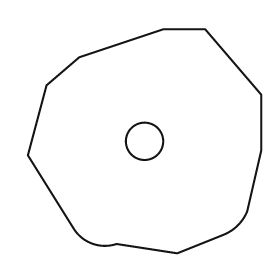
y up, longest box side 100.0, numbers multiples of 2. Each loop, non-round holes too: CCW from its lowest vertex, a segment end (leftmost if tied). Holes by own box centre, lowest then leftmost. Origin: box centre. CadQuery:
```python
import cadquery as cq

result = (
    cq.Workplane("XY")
    .moveTo(14.0, -48.0)
    .lineTo(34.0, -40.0)
    .threePointArc((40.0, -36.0), (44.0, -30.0))
    .lineTo(50.0, -4.0)
    .lineTo(50.0, 20.0)
    .lineTo(26.0, 48.0)
    .lineTo(8.0, 48.0)
    .lineTo(-28.0, 36.0)
    .lineTo(-42.0, 24.0)
    .lineTo(-50.0, -6.0)
    .lineTo(-30.0, -38.0)
    .threePointArc((-22.0, -44.0), (-12.0, -44.0))
    .close()
    .moveTo(0.0, 0.0)
    .circle(8.0)
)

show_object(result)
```